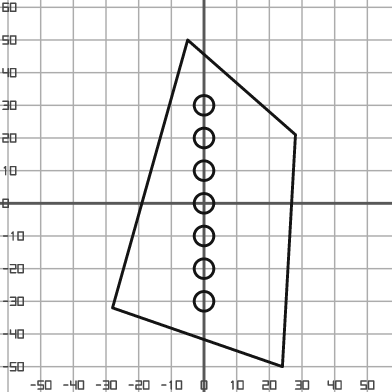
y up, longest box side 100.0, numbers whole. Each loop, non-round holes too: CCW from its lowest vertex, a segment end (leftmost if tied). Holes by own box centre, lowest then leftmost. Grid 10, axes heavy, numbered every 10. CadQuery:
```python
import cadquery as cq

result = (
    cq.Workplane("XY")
    .moveTo(24.0, -50.0)
    .lineTo(28.0, 21.0)
    .lineTo(-5.0, 50.0)
    .lineTo(-28.0, -32.0)
    .close()
    .moveTo(0.0, -30.0)
    .circle(3.0)
    .moveTo(0.0, -20.0)
    .circle(3.0)
    .moveTo(0.0, -10.0)
    .circle(3.0)
    .moveTo(0.0, 0.0)
    .circle(3.0)
    .moveTo(0.0, 10.0)
    .circle(3.0)
    .moveTo(0.0, 20.0)
    .circle(3.0)
    .moveTo(0.0, 30.0)
    .circle(3.0)
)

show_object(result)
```